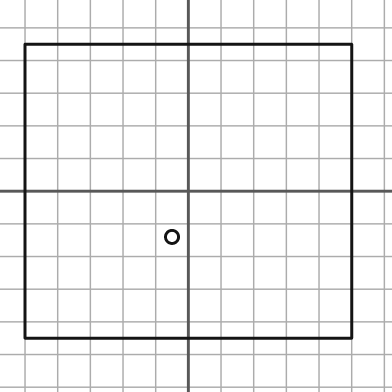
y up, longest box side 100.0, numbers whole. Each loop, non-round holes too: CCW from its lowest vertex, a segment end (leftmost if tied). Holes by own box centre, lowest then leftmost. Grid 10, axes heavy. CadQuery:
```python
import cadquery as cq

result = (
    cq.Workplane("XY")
    .moveTo(-50.0, -45.0)
    .lineTo(50.0, -45.0)
    .lineTo(50.0, 45.0)
    .lineTo(-50.0, 45.0)
    .close()
    .moveTo(-5.0, -14.0)
    .circle(2.0)
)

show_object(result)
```